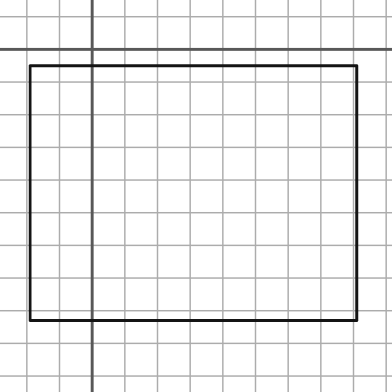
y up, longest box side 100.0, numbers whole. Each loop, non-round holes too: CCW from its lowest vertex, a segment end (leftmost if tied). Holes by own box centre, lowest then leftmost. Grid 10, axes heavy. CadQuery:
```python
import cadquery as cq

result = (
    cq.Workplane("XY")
    .moveTo(-19.0, -83.0)
    .lineTo(81.0, -83.0)
    .lineTo(81.0, -5.0)
    .lineTo(-19.0, -5.0)
    .close()
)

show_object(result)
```